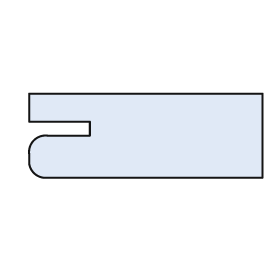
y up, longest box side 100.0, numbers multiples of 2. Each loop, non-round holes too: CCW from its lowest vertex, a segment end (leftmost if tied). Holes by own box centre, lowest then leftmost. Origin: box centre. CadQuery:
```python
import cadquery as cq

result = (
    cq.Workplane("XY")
    .moveTo(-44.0, -18.0)
    .lineTo(50.0, -18.0)
    .lineTo(50.0, 18.0)
    .lineTo(-50.0, 18.0)
    .lineTo(-50.0, 6.0)
    .lineTo(-24.0, 6.0)
    .lineTo(-24.0, 0.0)
    .lineTo(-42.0, 0.0)
    .threePointArc((-48.0, -2.0), (-50.0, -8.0))
    .lineTo(-50.0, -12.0)
    .threePointArc((-48.0, -16.0), (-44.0, -18.0))
    .close()
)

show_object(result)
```